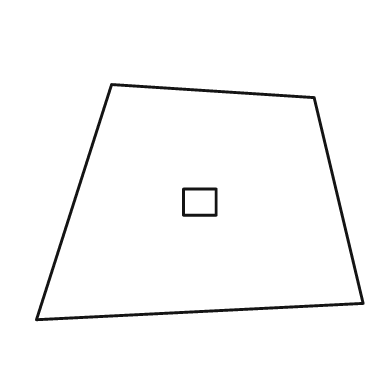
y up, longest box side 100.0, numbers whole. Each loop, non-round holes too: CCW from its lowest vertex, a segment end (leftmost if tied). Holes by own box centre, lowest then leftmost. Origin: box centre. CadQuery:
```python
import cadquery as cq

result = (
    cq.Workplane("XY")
    .moveTo(-50.0, -36.0)
    .lineTo(50.0, -31.0)
    .lineTo(35.0, 32.0)
    .lineTo(-27.0, 36.0)
    .close()
    .moveTo(-5.0, -4.0)
    .lineTo(5.0, -4.0)
    .lineTo(5.0, 4.0)
    .lineTo(-5.0, 4.0)
    .close()
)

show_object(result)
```